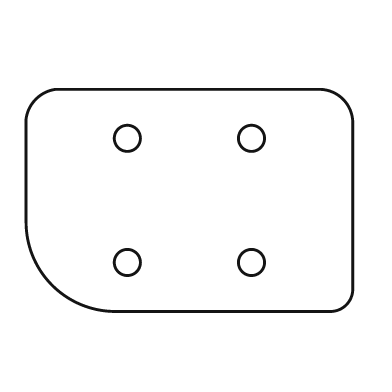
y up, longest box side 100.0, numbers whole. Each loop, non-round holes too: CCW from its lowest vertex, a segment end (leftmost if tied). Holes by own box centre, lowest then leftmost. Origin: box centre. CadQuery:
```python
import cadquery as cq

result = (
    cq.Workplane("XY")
    .moveTo(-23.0, -34.0)
    .lineTo(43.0, -34.0)
    .threePointArc((48.0, -32.0), (50.0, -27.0))
    .lineTo(50.0, 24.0)
    .threePointArc((47.0, 31.0), (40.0, 34.0))
    .lineTo(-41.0, 34.0)
    .threePointArc((-47.0, 31.0), (-50.0, 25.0))
    .lineTo(-50.0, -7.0)
    .threePointArc((-42.0, -26.0), (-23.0, -34.0))
    .close()
    .moveTo(-19.0, -19.0)
    .circle(4.0)
    .moveTo(19.0, -19.0)
    .circle(4.0)
    .moveTo(-19.0, 19.0)
    .circle(4.0)
    .moveTo(19.0, 19.0)
    .circle(4.0)
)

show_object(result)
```